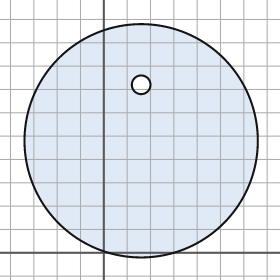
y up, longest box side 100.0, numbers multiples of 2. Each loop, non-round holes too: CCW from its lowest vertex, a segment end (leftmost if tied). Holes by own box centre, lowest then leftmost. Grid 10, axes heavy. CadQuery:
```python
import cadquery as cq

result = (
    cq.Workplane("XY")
    .moveTo(16.0, 48.0)
    .circle(50.0)
    .moveTo(16.0, 72.0)
    .circle(4.0)
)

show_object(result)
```